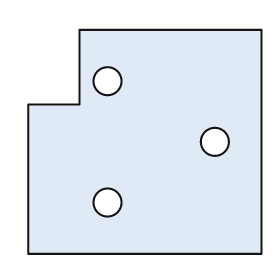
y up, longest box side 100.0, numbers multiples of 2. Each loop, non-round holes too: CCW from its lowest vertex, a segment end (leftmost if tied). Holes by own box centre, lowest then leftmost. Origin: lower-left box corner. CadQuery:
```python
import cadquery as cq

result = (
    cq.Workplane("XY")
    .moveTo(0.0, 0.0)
    .lineTo(100.0, 0.0)
    .lineTo(100.0, 96.0)
    .lineTo(22.0, 96.0)
    .lineTo(22.0, 64.0)
    .lineTo(0.0, 64.0)
    .close()
    .moveTo(34.0, 22.0)
    .circle(6.0)
    .moveTo(80.0, 48.0)
    .circle(6.0)
    .moveTo(34.0, 74.0)
    .circle(6.0)
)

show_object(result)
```